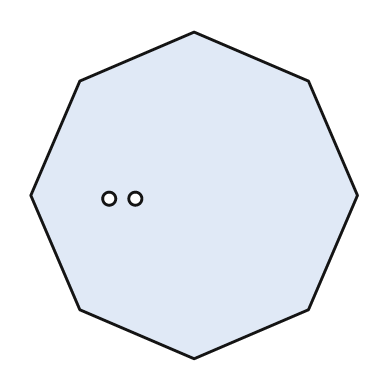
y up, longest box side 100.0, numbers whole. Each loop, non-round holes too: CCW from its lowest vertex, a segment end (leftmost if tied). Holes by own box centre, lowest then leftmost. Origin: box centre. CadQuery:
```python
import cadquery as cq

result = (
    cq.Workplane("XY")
    .moveTo(0.0, -50.0)
    .lineTo(35.0, -35.0)
    .lineTo(50.0, 0.0)
    .lineTo(35.0, 35.0)
    .lineTo(0.0, 50.0)
    .lineTo(-35.0, 35.0)
    .lineTo(-50.0, 0.0)
    .lineTo(-35.0, -35.0)
    .close()
    .moveTo(-26.0, -1.0)
    .circle(2.0)
    .moveTo(-18.0, -1.0)
    .circle(2.0)
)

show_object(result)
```